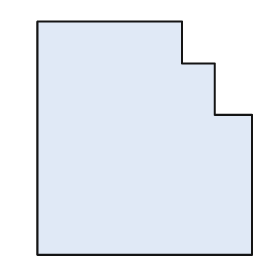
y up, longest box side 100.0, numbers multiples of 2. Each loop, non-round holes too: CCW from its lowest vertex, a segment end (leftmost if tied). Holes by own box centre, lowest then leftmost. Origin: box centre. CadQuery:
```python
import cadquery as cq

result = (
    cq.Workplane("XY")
    .moveTo(-46.0, -50.0)
    .lineTo(46.0, -50.0)
    .lineTo(46.0, 10.0)
    .lineTo(30.0, 10.0)
    .lineTo(30.0, 32.0)
    .lineTo(16.0, 32.0)
    .lineTo(16.0, 50.0)
    .lineTo(-46.0, 50.0)
    .close()
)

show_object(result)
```